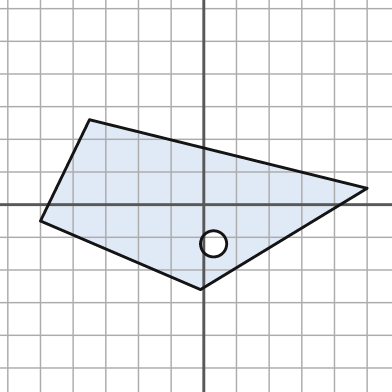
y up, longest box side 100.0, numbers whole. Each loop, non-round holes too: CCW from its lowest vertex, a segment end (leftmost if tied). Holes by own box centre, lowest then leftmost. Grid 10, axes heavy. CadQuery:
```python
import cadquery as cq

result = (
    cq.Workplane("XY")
    .moveTo(-1.0, -26.0)
    .lineTo(50.0, 5.0)
    .lineTo(-35.0, 26.0)
    .lineTo(-50.0, -5.0)
    .close()
    .moveTo(3.0, -12.0)
    .circle(4.0)
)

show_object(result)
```